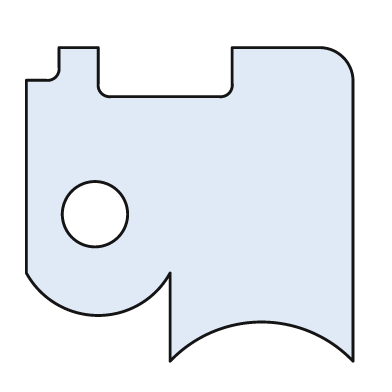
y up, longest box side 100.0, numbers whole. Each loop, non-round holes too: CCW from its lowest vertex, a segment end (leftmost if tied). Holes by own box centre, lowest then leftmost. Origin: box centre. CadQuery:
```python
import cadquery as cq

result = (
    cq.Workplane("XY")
    .moveTo(-6.0, -48.0)
    .threePointArc((22.0, -36.0), (50.0, -48.0))
    .lineTo(50.0, 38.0)
    .threePointArc((47.0, 45.0), (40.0, 48.0))
    .lineTo(13.0, 48.0)
    .lineTo(13.0, 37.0)
    .threePointArc((12.0, 34.0), (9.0, 33.0))
    .lineTo(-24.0, 33.0)
    .threePointArc((-27.0, 34.0), (-28.0, 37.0))
    .lineTo(-28.0, 48.0)
    .lineTo(-40.0, 48.0)
    .lineTo(-40.0, 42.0)
    .threePointArc((-41.0, 39.0), (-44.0, 38.0))
    .lineTo(-50.0, 38.0)
    .lineTo(-50.0, -21.0)
    .threePointArc((-28.0, -34.0), (-6.0, -21.0))
    .close()
    .moveTo(-29.0, -3.0)
    .circle(10.0)
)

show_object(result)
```